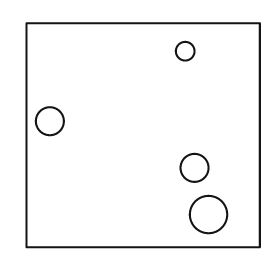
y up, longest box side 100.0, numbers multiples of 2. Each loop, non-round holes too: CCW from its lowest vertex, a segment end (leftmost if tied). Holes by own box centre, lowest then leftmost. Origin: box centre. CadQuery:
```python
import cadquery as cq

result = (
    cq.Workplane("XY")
    .moveTo(-50.0, -48.0)
    .lineTo(50.0, -48.0)
    .lineTo(50.0, 48.0)
    .lineTo(-50.0, 48.0)
    .close()
    .moveTo(28.0, -34.0)
    .circle(8.0)
    .moveTo(22.0, -14.0)
    .circle(6.0)
    .moveTo(-40.0, 6.0)
    .circle(6.0)
    .moveTo(18.0, 36.0)
    .circle(4.0)
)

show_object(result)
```